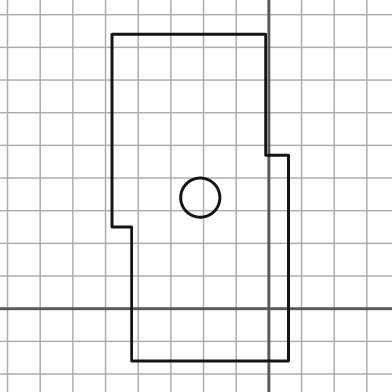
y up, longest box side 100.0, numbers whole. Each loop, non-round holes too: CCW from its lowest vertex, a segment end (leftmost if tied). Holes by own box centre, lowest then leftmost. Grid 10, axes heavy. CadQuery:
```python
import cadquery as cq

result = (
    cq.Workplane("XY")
    .moveTo(-42.0, -16.0)
    .lineTo(6.0, -16.0)
    .lineTo(6.0, 47.0)
    .lineTo(-1.0, 47.0)
    .lineTo(-1.0, 84.0)
    .lineTo(-48.0, 84.0)
    .lineTo(-48.0, 25.0)
    .lineTo(-42.0, 25.0)
    .close()
    .moveTo(-21.0, 34.0)
    .circle(6.0)
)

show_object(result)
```